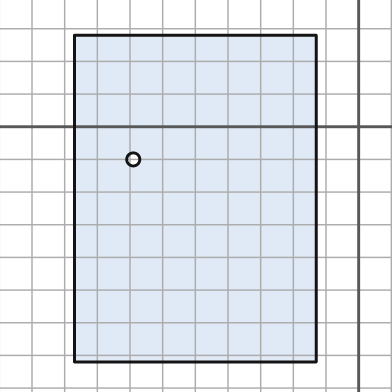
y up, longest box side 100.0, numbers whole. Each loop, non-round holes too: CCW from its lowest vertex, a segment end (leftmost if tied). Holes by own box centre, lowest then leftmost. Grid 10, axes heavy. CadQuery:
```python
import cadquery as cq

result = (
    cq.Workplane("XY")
    .moveTo(-87.0, -72.0)
    .lineTo(-13.0, -72.0)
    .lineTo(-13.0, 28.0)
    .lineTo(-87.0, 28.0)
    .close()
    .moveTo(-69.0, -10.0)
    .circle(2.0)
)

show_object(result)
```